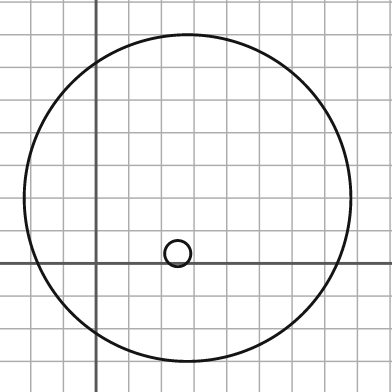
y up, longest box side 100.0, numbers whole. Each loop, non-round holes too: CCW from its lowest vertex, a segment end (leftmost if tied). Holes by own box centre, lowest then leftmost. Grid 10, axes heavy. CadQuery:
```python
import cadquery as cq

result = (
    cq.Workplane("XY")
    .moveTo(28.0, 20.0)
    .circle(50.0)
    .moveTo(25.0, 3.0)
    .circle(4.0)
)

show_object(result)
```